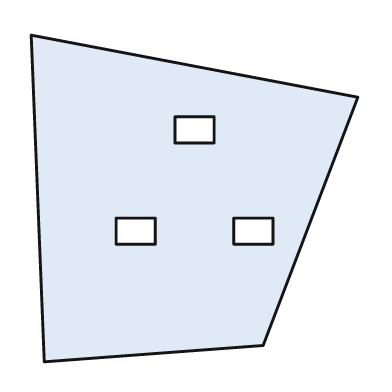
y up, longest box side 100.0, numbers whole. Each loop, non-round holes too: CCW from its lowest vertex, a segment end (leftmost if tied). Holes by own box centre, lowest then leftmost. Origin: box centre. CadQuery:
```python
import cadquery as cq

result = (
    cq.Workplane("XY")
    .moveTo(-46.0, -50.0)
    .lineTo(21.0, -45.0)
    .lineTo(50.0, 31.0)
    .lineTo(-50.0, 50.0)
    .close()
    .moveTo(-24.0, -14.0)
    .lineTo(-12.0, -14.0)
    .lineTo(-12.0, -6.0)
    .lineTo(-24.0, -6.0)
    .close()
    .moveTo(12.0, -14.0)
    .lineTo(24.0, -14.0)
    .lineTo(24.0, -6.0)
    .lineTo(12.0, -6.0)
    .close()
    .moveTo(-6.0, 17.0)
    .lineTo(6.0, 17.0)
    .lineTo(6.0, 25.0)
    .lineTo(-6.0, 25.0)
    .close()
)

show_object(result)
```